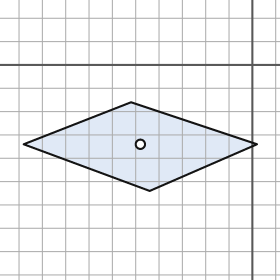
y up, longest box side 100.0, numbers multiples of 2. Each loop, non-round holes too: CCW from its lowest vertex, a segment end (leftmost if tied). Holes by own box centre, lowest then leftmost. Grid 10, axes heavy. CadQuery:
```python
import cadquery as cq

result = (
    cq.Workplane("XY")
    .moveTo(-44.0, -54.0)
    .lineTo(2.0, -34.0)
    .lineTo(-52.0, -16.0)
    .lineTo(-98.0, -34.0)
    .close()
    .moveTo(-48.0, -34.0)
    .circle(2.0)
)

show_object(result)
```